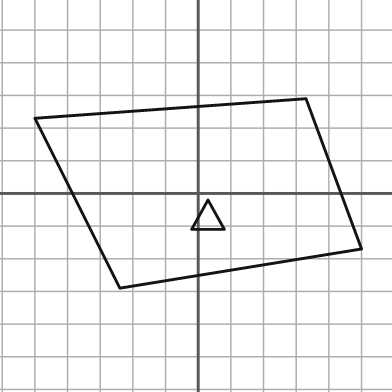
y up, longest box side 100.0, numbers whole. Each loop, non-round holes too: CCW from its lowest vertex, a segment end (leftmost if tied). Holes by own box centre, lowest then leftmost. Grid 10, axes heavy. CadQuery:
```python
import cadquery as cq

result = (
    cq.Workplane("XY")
    .moveTo(-24.0, -29.0)
    .lineTo(50.0, -17.0)
    .lineTo(33.0, 29.0)
    .lineTo(-50.0, 23.0)
    .close()
    .moveTo(-2.0, -11.0)
    .lineTo(8.0, -11.0)
    .lineTo(3.0, -2.0)
    .close()
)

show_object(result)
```